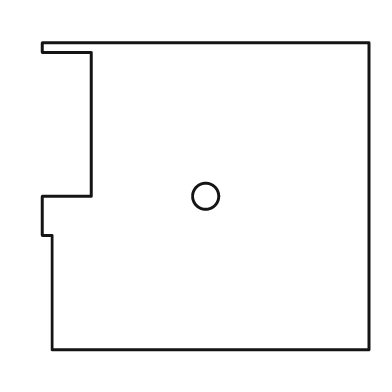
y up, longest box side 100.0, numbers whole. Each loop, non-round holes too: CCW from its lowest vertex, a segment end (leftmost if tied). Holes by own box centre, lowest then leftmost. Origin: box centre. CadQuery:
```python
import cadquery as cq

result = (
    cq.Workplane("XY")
    .moveTo(-47.0, -47.0)
    .lineTo(50.0, -47.0)
    .lineTo(50.0, 47.0)
    .lineTo(-50.0, 47.0)
    .lineTo(-50.0, 44.0)
    .lineTo(-35.0, 44.0)
    .lineTo(-35.0, 0.0)
    .lineTo(-50.0, 0.0)
    .lineTo(-50.0, -12.0)
    .lineTo(-47.0, -12.0)
    .close()
    .moveTo(0.0, 0.0)
    .circle(4.0)
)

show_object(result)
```